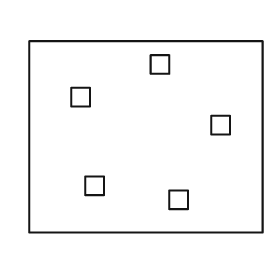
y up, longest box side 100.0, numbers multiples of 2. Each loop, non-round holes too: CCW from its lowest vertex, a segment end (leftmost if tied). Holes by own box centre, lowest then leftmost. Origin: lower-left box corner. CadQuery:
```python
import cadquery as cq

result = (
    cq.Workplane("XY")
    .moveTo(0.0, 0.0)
    .lineTo(100.0, 0.0)
    .lineTo(100.0, 82.0)
    .lineTo(0.0, 82.0)
    .close()
    .moveTo(60.0, 10.0)
    .lineTo(68.0, 10.0)
    .lineTo(68.0, 18.0)
    .lineTo(60.0, 18.0)
    .close()
    .moveTo(24.0, 16.0)
    .lineTo(32.0, 16.0)
    .lineTo(32.0, 24.0)
    .lineTo(24.0, 24.0)
    .close()
    .moveTo(78.0, 42.0)
    .lineTo(86.0, 42.0)
    .lineTo(86.0, 50.0)
    .lineTo(78.0, 50.0)
    .close()
    .moveTo(18.0, 54.0)
    .lineTo(26.0, 54.0)
    .lineTo(26.0, 62.0)
    .lineTo(18.0, 62.0)
    .close()
    .moveTo(52.0, 68.0)
    .lineTo(60.0, 68.0)
    .lineTo(60.0, 76.0)
    .lineTo(52.0, 76.0)
    .close()
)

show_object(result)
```